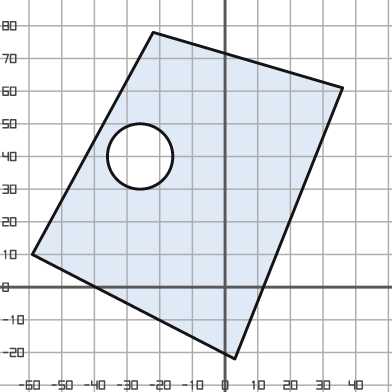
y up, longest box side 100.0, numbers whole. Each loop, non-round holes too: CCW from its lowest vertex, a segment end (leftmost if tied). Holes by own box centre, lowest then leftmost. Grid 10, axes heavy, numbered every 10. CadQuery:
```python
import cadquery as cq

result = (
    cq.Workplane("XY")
    .moveTo(3.0, -22.0)
    .lineTo(36.0, 61.0)
    .lineTo(-22.0, 78.0)
    .lineTo(-59.0, 10.0)
    .close()
    .moveTo(-26.0, 40.0)
    .circle(10.0)
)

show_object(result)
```